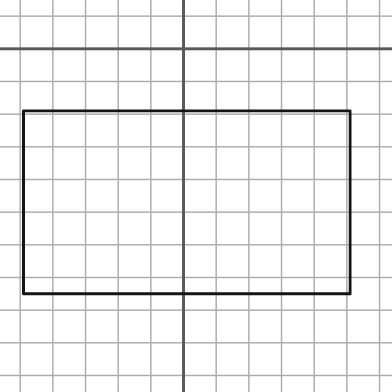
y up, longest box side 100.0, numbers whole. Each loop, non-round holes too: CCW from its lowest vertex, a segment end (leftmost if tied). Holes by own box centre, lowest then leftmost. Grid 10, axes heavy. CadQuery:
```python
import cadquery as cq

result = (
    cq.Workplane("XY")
    .moveTo(-49.0, -75.0)
    .lineTo(51.0, -75.0)
    .lineTo(51.0, -19.0)
    .lineTo(-49.0, -19.0)
    .close()
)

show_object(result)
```